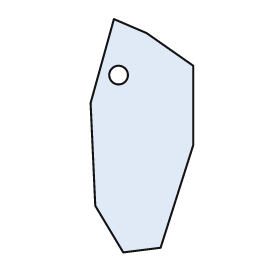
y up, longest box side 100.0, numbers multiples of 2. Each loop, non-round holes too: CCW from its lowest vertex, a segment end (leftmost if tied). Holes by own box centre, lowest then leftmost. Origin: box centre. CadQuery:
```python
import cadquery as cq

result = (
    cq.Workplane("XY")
    .moveTo(-8.0, -50.0)
    .lineTo(8.0, -48.0)
    .lineTo(22.0, -4.0)
    .lineTo(22.0, 30.0)
    .lineTo(2.0, 44.0)
    .lineTo(-12.0, 50.0)
    .lineTo(-22.0, 14.0)
    .lineTo(-20.0, -30.0)
    .close()
    .moveTo(-10.0, 26.0)
    .circle(4.0)
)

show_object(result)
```